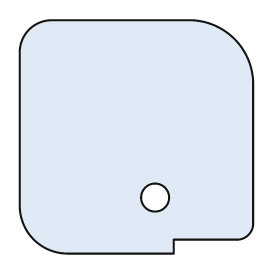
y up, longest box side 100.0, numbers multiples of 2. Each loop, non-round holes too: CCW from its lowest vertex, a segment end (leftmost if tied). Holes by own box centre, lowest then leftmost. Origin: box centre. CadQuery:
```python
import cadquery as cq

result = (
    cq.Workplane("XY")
    .moveTo(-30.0, -50.0)
    .lineTo(16.0, -50.0)
    .lineTo(16.0, -44.0)
    .lineTo(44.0, -44.0)
    .threePointArc((48.0, -42.0), (50.0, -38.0))
    .lineTo(50.0, 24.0)
    .threePointArc((42.0, 42.0), (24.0, 50.0))
    .lineTo(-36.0, 50.0)
    .threePointArc((-46.0, 46.0), (-50.0, 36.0))
    .lineTo(-50.0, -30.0)
    .threePointArc((-44.0, -44.0), (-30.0, -50.0))
    .close()
    .moveTo(8.0, -26.0)
    .circle(6.0)
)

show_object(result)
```